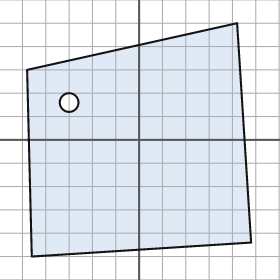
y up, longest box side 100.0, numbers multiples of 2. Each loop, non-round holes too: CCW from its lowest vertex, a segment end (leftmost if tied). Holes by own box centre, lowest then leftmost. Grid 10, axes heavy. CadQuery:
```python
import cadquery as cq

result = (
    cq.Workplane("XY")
    .moveTo(-46.0, -50.0)
    .lineTo(48.0, -44.0)
    .lineTo(42.0, 50.0)
    .lineTo(-48.0, 30.0)
    .close()
    .moveTo(-30.0, 16.0)
    .circle(4.0)
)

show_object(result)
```